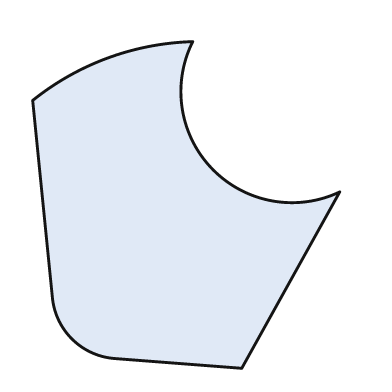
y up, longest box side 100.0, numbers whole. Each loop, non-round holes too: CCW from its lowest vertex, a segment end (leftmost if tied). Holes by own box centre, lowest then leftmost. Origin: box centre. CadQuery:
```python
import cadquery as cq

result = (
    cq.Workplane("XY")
    .moveTo(17.0, -50.0)
    .lineTo(47.0, 4.0)
    .threePointArc((8.0, 11.0), (2.0, 50.0))
    .threePointArc((-24.0, 45.0), (-47.0, 32.0))
    .lineTo(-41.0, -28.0)
    .threePointArc((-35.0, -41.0), (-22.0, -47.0))
    .close()
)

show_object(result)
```